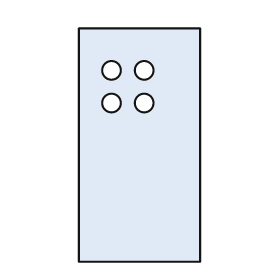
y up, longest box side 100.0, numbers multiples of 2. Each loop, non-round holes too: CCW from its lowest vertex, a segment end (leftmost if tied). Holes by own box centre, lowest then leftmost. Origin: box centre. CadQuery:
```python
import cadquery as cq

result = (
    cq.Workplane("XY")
    .moveTo(-26.0, -50.0)
    .lineTo(26.0, -50.0)
    .lineTo(26.0, 50.0)
    .lineTo(-26.0, 50.0)
    .close()
    .moveTo(-12.0, 18.0)
    .circle(4.0)
    .moveTo(2.0, 18.0)
    .circle(4.0)
    .moveTo(-12.0, 32.0)
    .circle(4.0)
    .moveTo(2.0, 32.0)
    .circle(4.0)
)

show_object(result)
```